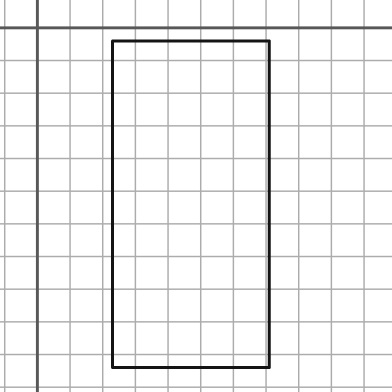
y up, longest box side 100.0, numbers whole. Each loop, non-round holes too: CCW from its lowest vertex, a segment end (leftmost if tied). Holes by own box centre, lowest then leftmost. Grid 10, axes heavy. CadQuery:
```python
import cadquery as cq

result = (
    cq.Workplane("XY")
    .moveTo(23.0, -104.0)
    .lineTo(71.0, -104.0)
    .lineTo(71.0, -4.0)
    .lineTo(23.0, -4.0)
    .close()
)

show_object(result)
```